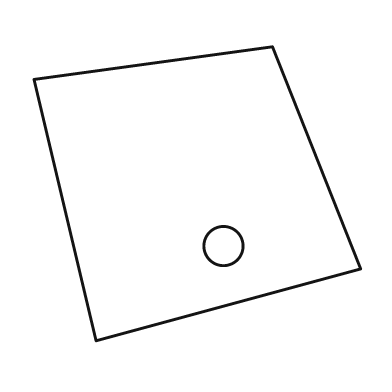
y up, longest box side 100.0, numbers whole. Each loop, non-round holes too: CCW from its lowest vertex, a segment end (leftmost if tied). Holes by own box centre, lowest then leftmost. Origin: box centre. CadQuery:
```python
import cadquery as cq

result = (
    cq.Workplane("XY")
    .moveTo(-31.0, -45.0)
    .lineTo(50.0, -23.0)
    .lineTo(23.0, 45.0)
    .lineTo(-50.0, 35.0)
    .close()
    .moveTo(8.0, -16.0)
    .circle(6.0)
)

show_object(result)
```